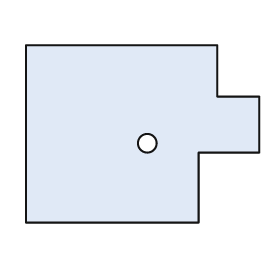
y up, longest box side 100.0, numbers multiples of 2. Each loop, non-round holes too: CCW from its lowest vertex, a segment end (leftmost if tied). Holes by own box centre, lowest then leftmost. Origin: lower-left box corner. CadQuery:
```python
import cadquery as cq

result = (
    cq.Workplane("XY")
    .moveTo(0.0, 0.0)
    .lineTo(74.0, 0.0)
    .lineTo(74.0, 30.0)
    .lineTo(100.0, 30.0)
    .lineTo(100.0, 54.0)
    .lineTo(82.0, 54.0)
    .lineTo(82.0, 76.0)
    .lineTo(0.0, 76.0)
    .close()
    .moveTo(52.0, 34.0)
    .circle(4.0)
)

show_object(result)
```